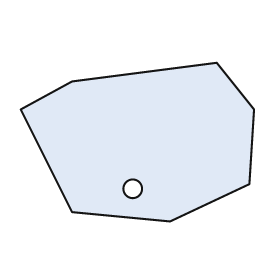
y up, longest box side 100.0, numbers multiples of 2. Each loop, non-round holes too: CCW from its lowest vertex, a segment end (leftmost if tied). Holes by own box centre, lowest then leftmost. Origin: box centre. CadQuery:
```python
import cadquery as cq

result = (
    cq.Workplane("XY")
    .moveTo(14.0, -34.0)
    .lineTo(48.0, -18.0)
    .lineTo(50.0, 14.0)
    .lineTo(34.0, 34.0)
    .lineTo(-28.0, 26.0)
    .lineTo(-50.0, 14.0)
    .lineTo(-28.0, -30.0)
    .close()
    .moveTo(-2.0, -20.0)
    .circle(4.0)
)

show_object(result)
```